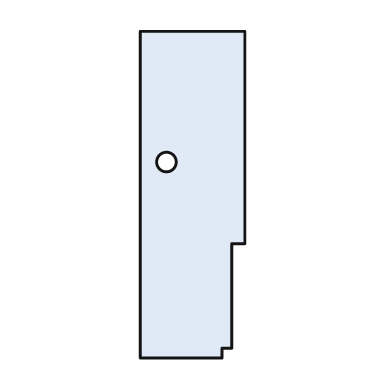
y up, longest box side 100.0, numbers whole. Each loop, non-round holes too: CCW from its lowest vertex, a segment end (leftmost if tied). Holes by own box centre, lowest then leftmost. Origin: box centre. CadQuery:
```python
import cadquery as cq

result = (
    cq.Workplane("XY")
    .moveTo(-16.0, -50.0)
    .lineTo(9.0, -50.0)
    .lineTo(9.0, -47.0)
    .lineTo(12.0, -47.0)
    .lineTo(12.0, -15.0)
    .lineTo(16.0, -15.0)
    .lineTo(16.0, 50.0)
    .lineTo(-16.0, 50.0)
    .close()
    .moveTo(-8.0, 10.0)
    .circle(3.0)
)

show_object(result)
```